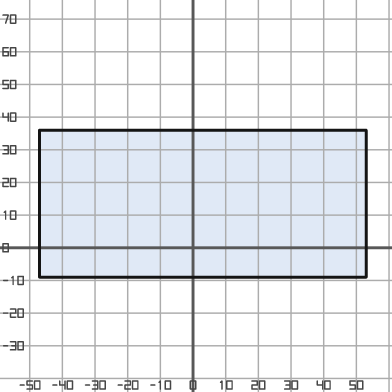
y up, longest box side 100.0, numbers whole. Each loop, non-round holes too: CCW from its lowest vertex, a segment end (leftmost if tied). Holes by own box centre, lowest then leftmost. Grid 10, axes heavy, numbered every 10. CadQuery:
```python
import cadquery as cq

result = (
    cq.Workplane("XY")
    .moveTo(-47.0, -9.0)
    .lineTo(53.0, -9.0)
    .lineTo(53.0, 36.0)
    .lineTo(-47.0, 36.0)
    .close()
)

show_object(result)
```